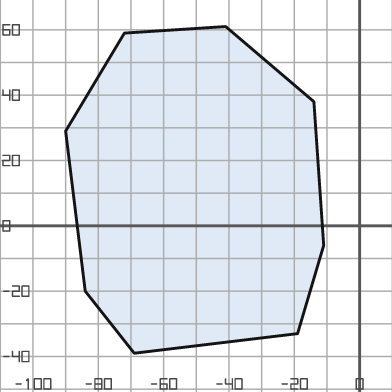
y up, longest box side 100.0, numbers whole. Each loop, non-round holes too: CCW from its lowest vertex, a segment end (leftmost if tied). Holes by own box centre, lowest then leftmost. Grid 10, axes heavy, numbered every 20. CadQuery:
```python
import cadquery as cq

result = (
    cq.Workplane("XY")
    .moveTo(-69.0, -39.0)
    .lineTo(-19.0, -33.0)
    .lineTo(-11.0, -6.0)
    .lineTo(-14.0, 38.0)
    .lineTo(-41.0, 61.0)
    .lineTo(-72.0, 59.0)
    .lineTo(-90.0, 29.0)
    .lineTo(-84.0, -20.0)
    .close()
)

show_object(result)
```